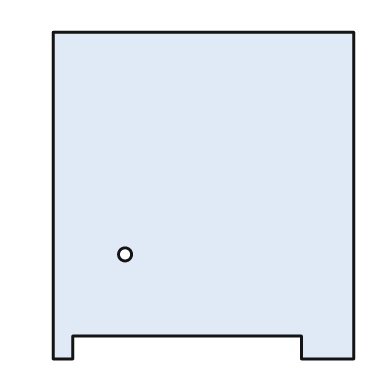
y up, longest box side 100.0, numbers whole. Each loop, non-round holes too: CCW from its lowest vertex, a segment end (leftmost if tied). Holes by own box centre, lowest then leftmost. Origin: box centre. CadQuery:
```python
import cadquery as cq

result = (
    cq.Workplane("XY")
    .moveTo(-46.0, -50.0)
    .lineTo(-40.0, -50.0)
    .lineTo(-40.0, -43.0)
    .lineTo(30.0, -43.0)
    .lineTo(30.0, -50.0)
    .lineTo(46.0, -50.0)
    .lineTo(46.0, 50.0)
    .lineTo(-46.0, 50.0)
    .close()
    .moveTo(-24.0, -18.0)
    .circle(2.0)
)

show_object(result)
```